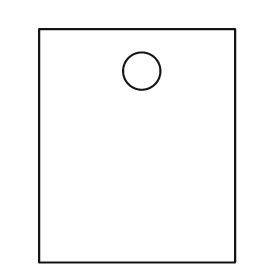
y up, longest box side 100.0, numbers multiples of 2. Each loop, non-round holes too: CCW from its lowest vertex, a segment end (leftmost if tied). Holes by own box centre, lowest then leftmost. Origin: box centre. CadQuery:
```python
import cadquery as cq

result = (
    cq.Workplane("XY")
    .moveTo(-42.0, -50.0)
    .lineTo(42.0, -50.0)
    .lineTo(42.0, 50.0)
    .lineTo(-42.0, 50.0)
    .close()
    .moveTo(2.0, 32.0)
    .circle(8.0)
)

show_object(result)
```